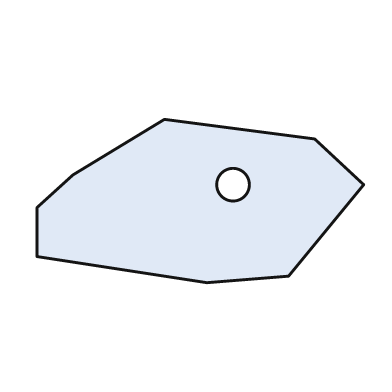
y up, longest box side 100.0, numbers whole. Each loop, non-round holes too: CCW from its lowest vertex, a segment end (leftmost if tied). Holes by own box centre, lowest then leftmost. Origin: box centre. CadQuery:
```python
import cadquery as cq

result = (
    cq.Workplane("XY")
    .moveTo(2.0, -25.0)
    .lineTo(27.0, -23.0)
    .lineTo(50.0, 5.0)
    .lineTo(35.0, 19.0)
    .lineTo(-11.0, 25.0)
    .lineTo(-39.0, 8.0)
    .lineTo(-50.0, -2.0)
    .lineTo(-50.0, -17.0)
    .close()
    .moveTo(10.0, 5.0)
    .circle(5.0)
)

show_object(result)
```